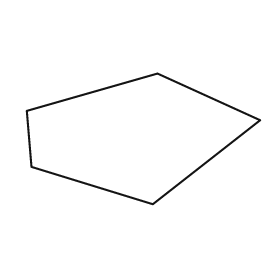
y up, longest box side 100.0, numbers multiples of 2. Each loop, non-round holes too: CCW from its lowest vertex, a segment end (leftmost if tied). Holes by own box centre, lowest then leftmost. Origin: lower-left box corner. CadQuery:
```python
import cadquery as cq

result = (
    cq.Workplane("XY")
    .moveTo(54.0, 0.0)
    .lineTo(100.0, 36.0)
    .lineTo(56.0, 56.0)
    .lineTo(0.0, 40.0)
    .lineTo(2.0, 16.0)
    .close()
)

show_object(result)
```